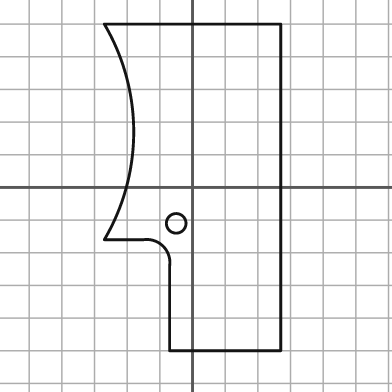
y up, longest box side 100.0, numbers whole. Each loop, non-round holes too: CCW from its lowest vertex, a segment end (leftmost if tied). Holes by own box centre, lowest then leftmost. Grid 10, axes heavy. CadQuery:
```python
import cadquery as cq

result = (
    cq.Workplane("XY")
    .moveTo(-7.0, -50.0)
    .lineTo(27.0, -50.0)
    .lineTo(27.0, 50.0)
    .lineTo(-27.0, 50.0)
    .threePointArc((-18.0, 17.0), (-27.0, -16.0))
    .lineTo(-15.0, -16.0)
    .threePointArc((-9.0, -18.0), (-7.0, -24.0))
    .close()
    .moveTo(-5.0, -11.0)
    .circle(3.0)
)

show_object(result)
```